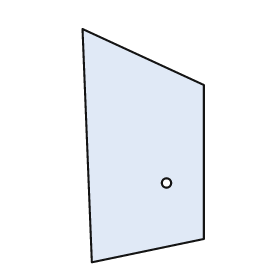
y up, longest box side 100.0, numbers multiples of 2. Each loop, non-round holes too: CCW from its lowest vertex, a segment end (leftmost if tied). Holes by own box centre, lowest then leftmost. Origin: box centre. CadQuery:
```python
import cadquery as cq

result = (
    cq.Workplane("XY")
    .moveTo(-22.0, -50.0)
    .lineTo(26.0, -40.0)
    .lineTo(26.0, 26.0)
    .lineTo(-26.0, 50.0)
    .close()
    .moveTo(10.0, -16.0)
    .circle(2.0)
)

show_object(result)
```